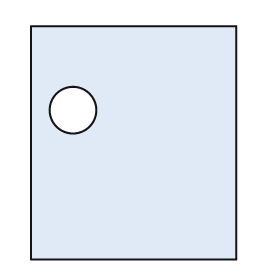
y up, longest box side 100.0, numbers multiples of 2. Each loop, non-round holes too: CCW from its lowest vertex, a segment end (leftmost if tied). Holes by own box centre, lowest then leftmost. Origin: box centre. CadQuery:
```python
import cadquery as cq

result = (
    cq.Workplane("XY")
    .moveTo(-44.0, -50.0)
    .lineTo(44.0, -50.0)
    .lineTo(44.0, 50.0)
    .lineTo(-44.0, 50.0)
    .close()
    .moveTo(-26.0, 14.0)
    .circle(10.0)
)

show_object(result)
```